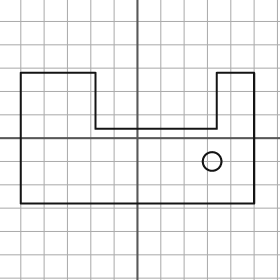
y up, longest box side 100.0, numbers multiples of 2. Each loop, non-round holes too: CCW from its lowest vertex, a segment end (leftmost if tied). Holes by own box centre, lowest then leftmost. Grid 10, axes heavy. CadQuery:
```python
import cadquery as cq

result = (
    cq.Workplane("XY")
    .moveTo(-50.0, -28.0)
    .lineTo(50.0, -28.0)
    .lineTo(50.0, 28.0)
    .lineTo(34.0, 28.0)
    .lineTo(34.0, 4.0)
    .lineTo(-18.0, 4.0)
    .lineTo(-18.0, 28.0)
    .lineTo(-50.0, 28.0)
    .close()
    .moveTo(32.0, -10.0)
    .circle(4.0)
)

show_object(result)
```